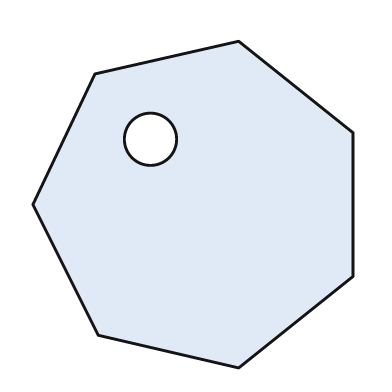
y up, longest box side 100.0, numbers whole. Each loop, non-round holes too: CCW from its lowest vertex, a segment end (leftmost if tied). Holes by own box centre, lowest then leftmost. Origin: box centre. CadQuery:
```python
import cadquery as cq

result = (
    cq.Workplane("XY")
    .moveTo(14.0, -50.0)
    .lineTo(49.0, -22.0)
    .lineTo(49.0, 22.0)
    .lineTo(14.0, 50.0)
    .lineTo(-30.0, 40.0)
    .lineTo(-49.0, 0.0)
    .lineTo(-29.0, -40.0)
    .close()
    .moveTo(-13.0, 20.0)
    .circle(8.0)
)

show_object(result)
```